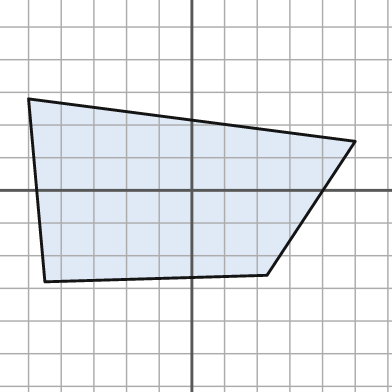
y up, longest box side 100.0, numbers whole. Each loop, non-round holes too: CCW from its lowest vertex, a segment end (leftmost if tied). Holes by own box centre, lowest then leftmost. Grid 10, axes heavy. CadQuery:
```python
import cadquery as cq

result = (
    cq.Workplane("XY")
    .moveTo(-45.0, -28.0)
    .lineTo(23.0, -26.0)
    .lineTo(50.0, 15.0)
    .lineTo(-50.0, 28.0)
    .close()
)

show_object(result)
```